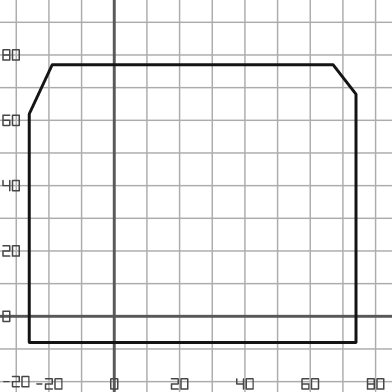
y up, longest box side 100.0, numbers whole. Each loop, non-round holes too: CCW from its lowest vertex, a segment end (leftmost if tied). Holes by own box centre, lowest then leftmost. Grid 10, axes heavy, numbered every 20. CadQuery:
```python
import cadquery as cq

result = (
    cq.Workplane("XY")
    .moveTo(-26.0, -8.0)
    .lineTo(74.0, -8.0)
    .lineTo(74.0, 68.0)
    .lineTo(67.0, 77.0)
    .lineTo(-19.0, 77.0)
    .lineTo(-26.0, 62.0)
    .close()
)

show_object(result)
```